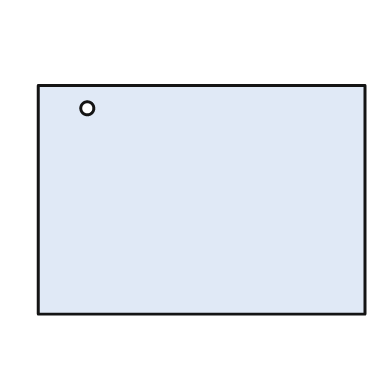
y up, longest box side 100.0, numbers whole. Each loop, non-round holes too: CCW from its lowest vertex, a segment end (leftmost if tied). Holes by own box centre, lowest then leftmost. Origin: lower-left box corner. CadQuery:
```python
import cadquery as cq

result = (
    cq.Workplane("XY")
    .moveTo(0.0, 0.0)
    .lineTo(100.0, 0.0)
    .lineTo(100.0, 70.0)
    .lineTo(0.0, 70.0)
    .close()
    .moveTo(15.0, 63.0)
    .circle(2.0)
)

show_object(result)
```